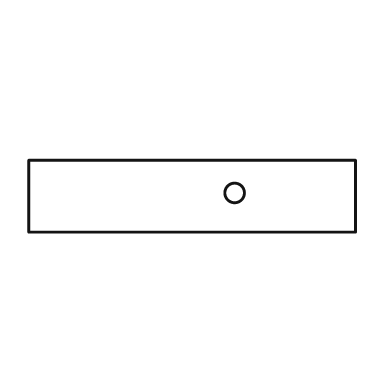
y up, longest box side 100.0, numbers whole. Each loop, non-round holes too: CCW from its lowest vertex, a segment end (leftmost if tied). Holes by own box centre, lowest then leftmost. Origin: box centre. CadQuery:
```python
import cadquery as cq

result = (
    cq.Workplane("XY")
    .moveTo(-50.0, -11.0)
    .lineTo(50.0, -11.0)
    .lineTo(50.0, 11.0)
    .lineTo(-50.0, 11.0)
    .close()
    .moveTo(13.0, 1.0)
    .circle(3.0)
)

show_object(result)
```